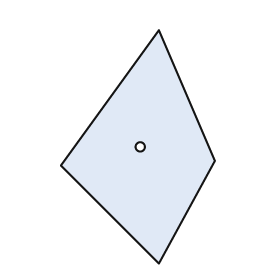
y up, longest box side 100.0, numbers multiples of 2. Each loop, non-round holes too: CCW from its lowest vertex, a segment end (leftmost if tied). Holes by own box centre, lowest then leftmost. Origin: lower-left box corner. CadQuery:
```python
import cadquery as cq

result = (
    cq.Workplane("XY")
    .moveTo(42.0, 0.0)
    .lineTo(66.0, 44.0)
    .lineTo(42.0, 100.0)
    .lineTo(0.0, 42.0)
    .close()
    .moveTo(34.0, 50.0)
    .circle(2.0)
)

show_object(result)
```